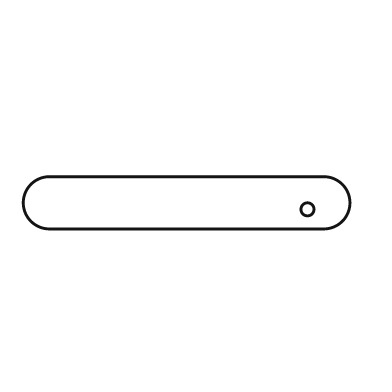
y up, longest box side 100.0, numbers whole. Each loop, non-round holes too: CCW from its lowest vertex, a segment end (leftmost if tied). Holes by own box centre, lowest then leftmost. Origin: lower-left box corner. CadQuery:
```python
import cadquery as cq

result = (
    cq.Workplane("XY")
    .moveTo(8.0, 0.0)
    .lineTo(92.0, 0.0)
    .threePointArc((100.0, 8.0), (92.0, 16.0))
    .lineTo(8.0, 16.0)
    .threePointArc((0.0, 8.0), (8.0, 0.0))
    .close()
    .moveTo(87.0, 6.0)
    .circle(2.0)
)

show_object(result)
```